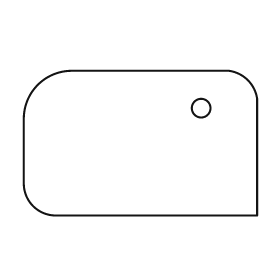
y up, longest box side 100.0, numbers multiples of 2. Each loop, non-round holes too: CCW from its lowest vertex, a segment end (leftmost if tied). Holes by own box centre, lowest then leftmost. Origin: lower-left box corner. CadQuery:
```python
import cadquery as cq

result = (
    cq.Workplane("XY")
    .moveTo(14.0, 0.0)
    .lineTo(100.0, 0.0)
    .lineTo(100.0, 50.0)
    .threePointArc((96.0, 58.0), (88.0, 62.0))
    .lineTo(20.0, 62.0)
    .threePointArc((6.0, 56.0), (0.0, 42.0))
    .lineTo(0.0, 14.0)
    .threePointArc((4.0, 4.0), (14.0, 0.0))
    .close()
    .moveTo(76.0, 46.0)
    .circle(4.0)
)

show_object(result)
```